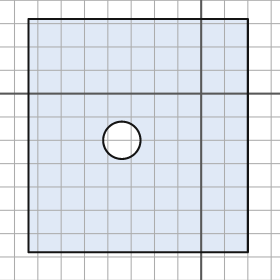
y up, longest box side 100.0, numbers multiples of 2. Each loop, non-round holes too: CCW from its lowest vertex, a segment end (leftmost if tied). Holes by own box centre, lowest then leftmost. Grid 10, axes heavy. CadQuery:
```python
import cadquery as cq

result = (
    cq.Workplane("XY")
    .moveTo(-74.0, -68.0)
    .lineTo(20.0, -68.0)
    .lineTo(20.0, 32.0)
    .lineTo(-74.0, 32.0)
    .close()
    .moveTo(-34.0, -20.0)
    .circle(8.0)
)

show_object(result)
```